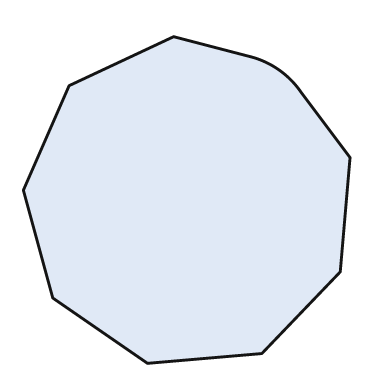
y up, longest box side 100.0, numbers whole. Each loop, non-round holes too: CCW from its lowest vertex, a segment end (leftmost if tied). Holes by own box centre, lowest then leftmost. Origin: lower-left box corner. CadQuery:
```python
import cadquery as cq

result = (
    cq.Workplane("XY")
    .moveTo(38.0, 0.0)
    .lineTo(73.0, 3.0)
    .lineTo(97.0, 28.0)
    .lineTo(100.0, 63.0)
    .lineTo(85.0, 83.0)
    .threePointArc((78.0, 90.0), (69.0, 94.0))
    .lineTo(46.0, 100.0)
    .lineTo(14.0, 85.0)
    .lineTo(0.0, 53.0)
    .lineTo(9.0, 20.0)
    .close()
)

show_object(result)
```